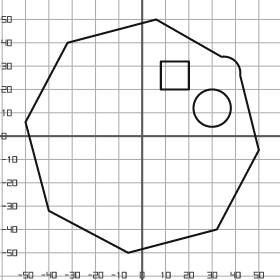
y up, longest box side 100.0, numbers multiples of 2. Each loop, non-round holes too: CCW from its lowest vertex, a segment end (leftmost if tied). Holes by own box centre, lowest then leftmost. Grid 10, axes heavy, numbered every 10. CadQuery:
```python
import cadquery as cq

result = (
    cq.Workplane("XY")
    .moveTo(-6.0, -50.0)
    .lineTo(32.0, -40.0)
    .lineTo(50.0, -6.0)
    .lineTo(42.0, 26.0)
    .threePointArc((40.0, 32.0), (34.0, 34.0))
    .lineTo(6.0, 50.0)
    .lineTo(-32.0, 40.0)
    .lineTo(-50.0, 6.0)
    .lineTo(-40.0, -32.0)
    .close()
    .moveTo(30.0, 12.0)
    .circle(8.0)
    .moveTo(8.0, 20.0)
    .lineTo(20.0, 20.0)
    .lineTo(20.0, 32.0)
    .lineTo(8.0, 32.0)
    .close()
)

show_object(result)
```